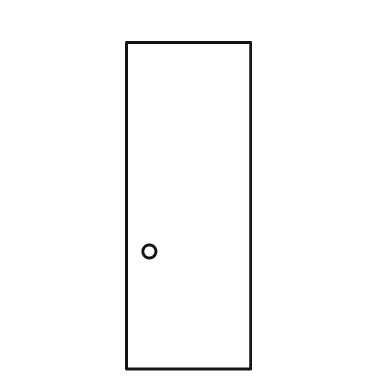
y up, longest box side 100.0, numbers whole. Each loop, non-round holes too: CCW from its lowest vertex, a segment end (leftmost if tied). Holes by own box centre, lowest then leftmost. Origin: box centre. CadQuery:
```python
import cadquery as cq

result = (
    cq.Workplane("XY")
    .moveTo(-19.0, -50.0)
    .lineTo(19.0, -50.0)
    .lineTo(19.0, 50.0)
    .lineTo(-19.0, 50.0)
    .close()
    .moveTo(-12.0, -14.0)
    .circle(2.0)
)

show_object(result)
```